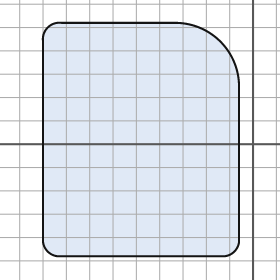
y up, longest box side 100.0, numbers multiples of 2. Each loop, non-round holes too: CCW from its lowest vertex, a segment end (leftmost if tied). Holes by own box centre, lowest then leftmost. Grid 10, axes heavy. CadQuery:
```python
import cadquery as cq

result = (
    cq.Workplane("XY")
    .moveTo(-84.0, -48.0)
    .lineTo(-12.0, -48.0)
    .threePointArc((-8.0, -46.0), (-6.0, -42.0))
    .lineTo(-6.0, 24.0)
    .threePointArc((-14.0, 44.0), (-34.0, 52.0))
    .lineTo(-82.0, 52.0)
    .threePointArc((-88.0, 50.0), (-90.0, 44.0))
    .lineTo(-90.0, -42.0)
    .threePointArc((-88.0, -46.0), (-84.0, -48.0))
    .close()
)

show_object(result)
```